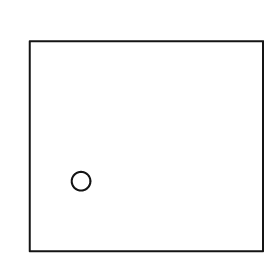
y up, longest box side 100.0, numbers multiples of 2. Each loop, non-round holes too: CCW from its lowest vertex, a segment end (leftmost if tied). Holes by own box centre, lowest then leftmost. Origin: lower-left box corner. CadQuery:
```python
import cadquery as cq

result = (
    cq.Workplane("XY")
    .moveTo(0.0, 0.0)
    .lineTo(100.0, 0.0)
    .lineTo(100.0, 90.0)
    .lineTo(0.0, 90.0)
    .close()
    .moveTo(22.0, 30.0)
    .circle(4.0)
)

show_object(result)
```